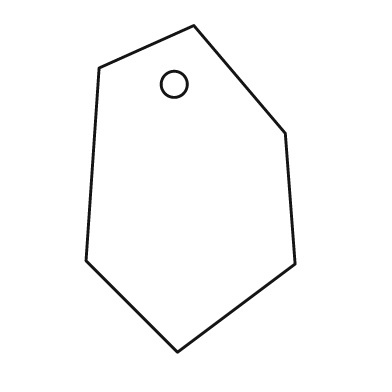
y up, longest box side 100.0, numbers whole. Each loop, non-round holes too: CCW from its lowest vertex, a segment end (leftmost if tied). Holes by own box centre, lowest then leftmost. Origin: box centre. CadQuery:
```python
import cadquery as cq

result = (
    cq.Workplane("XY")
    .moveTo(-4.0, -50.0)
    .lineTo(32.0, -23.0)
    .lineTo(29.0, 17.0)
    .lineTo(1.0, 50.0)
    .lineTo(-28.0, 37.0)
    .lineTo(-32.0, -22.0)
    .close()
    .moveTo(-5.0, 32.0)
    .circle(4.0)
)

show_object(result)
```